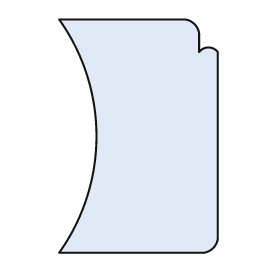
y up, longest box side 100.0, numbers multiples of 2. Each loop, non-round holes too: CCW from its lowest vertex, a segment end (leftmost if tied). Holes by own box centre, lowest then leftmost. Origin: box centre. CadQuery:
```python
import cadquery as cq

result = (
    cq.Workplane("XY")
    .moveTo(-34.0, -50.0)
    .lineTo(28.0, -50.0)
    .threePointArc((32.0, -48.0), (34.0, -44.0))
    .lineTo(34.0, 36.0)
    .threePointArc((30.0, 38.0), (26.0, 36.0))
    .lineTo(26.0, 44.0)
    .threePointArc((24.0, 48.0), (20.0, 50.0))
    .lineTo(-34.0, 50.0)
    .threePointArc((-18.0, 0.0), (-34.0, -50.0))
    .close()
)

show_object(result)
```